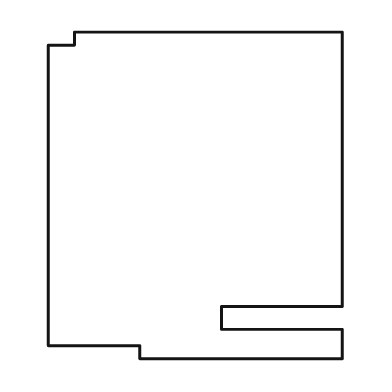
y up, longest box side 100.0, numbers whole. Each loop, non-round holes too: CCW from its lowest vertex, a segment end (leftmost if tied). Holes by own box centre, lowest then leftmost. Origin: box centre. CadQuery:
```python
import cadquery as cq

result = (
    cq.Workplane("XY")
    .moveTo(-17.0, -50.0)
    .lineTo(45.0, -50.0)
    .lineTo(45.0, -41.0)
    .lineTo(8.0, -41.0)
    .lineTo(8.0, -34.0)
    .lineTo(45.0, -34.0)
    .lineTo(45.0, 50.0)
    .lineTo(-37.0, 50.0)
    .lineTo(-37.0, 46.0)
    .lineTo(-45.0, 46.0)
    .lineTo(-45.0, -46.0)
    .lineTo(-17.0, -46.0)
    .close()
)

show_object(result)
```